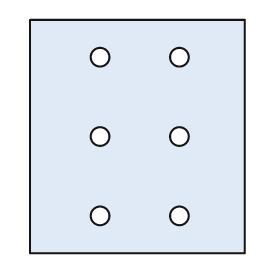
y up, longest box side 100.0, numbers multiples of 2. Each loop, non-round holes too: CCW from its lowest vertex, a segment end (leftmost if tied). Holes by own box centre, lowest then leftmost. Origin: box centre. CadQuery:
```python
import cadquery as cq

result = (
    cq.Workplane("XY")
    .moveTo(-46.0, -50.0)
    .lineTo(46.0, -50.0)
    .lineTo(46.0, 50.0)
    .lineTo(-46.0, 50.0)
    .close()
    .moveTo(-16.0, -34.0)
    .circle(4.0)
    .moveTo(18.0, -34.0)
    .circle(4.0)
    .moveTo(-16.0, 0.0)
    .circle(4.0)
    .moveTo(18.0, 0.0)
    .circle(4.0)
    .moveTo(-16.0, 34.0)
    .circle(4.0)
    .moveTo(18.0, 34.0)
    .circle(4.0)
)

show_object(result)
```